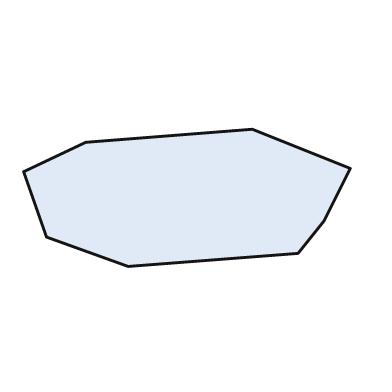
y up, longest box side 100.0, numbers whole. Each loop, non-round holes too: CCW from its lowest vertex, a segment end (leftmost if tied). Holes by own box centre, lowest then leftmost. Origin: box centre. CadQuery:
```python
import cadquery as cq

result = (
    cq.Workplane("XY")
    .moveTo(-18.0, -21.0)
    .lineTo(34.0, -17.0)
    .lineTo(42.0, -7.0)
    .lineTo(50.0, 9.0)
    .lineTo(20.0, 21.0)
    .lineTo(-31.0, 17.0)
    .lineTo(-50.0, 8.0)
    .lineTo(-43.0, -12.0)
    .close()
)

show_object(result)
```